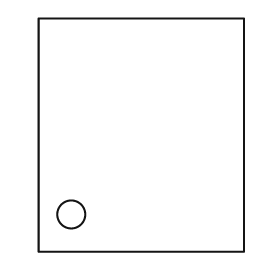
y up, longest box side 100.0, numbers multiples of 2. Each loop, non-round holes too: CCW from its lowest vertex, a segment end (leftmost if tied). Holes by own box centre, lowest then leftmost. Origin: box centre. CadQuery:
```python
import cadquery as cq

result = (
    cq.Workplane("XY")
    .moveTo(-44.0, -50.0)
    .lineTo(44.0, -50.0)
    .lineTo(44.0, 50.0)
    .lineTo(-44.0, 50.0)
    .close()
    .moveTo(-30.0, -34.0)
    .circle(6.0)
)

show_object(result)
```